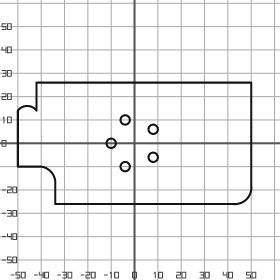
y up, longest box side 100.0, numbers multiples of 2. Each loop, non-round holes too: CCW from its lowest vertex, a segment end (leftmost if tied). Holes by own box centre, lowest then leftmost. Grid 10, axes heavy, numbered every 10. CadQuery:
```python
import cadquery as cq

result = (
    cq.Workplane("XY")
    .moveTo(-34.0, -26.0)
    .lineTo(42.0, -26.0)
    .threePointArc((48.0, -24.0), (50.0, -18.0))
    .lineTo(50.0, 26.0)
    .lineTo(-42.0, 26.0)
    .lineTo(-42.0, 14.0)
    .threePointArc((-46.0, 16.0), (-50.0, 14.0))
    .lineTo(-50.0, -10.0)
    .lineTo(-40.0, -10.0)
    .threePointArc((-36.0, -12.0), (-34.0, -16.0))
    .close()
    .moveTo(-4.0, -10.0)
    .circle(2.0)
    .moveTo(8.0, -6.0)
    .circle(2.0)
    .moveTo(-10.0, 0.0)
    .circle(2.0)
    .moveTo(8.0, 6.0)
    .circle(2.0)
    .moveTo(-4.0, 10.0)
    .circle(2.0)
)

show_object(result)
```